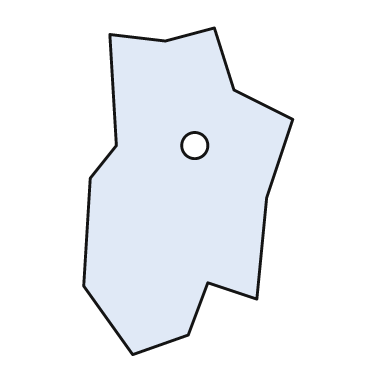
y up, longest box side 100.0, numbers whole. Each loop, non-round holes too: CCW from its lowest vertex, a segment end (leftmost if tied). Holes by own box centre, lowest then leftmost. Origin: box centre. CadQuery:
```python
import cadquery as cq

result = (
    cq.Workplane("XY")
    .moveTo(-17.0, -50.0)
    .lineTo(0.0, -44.0)
    .lineTo(6.0, -28.0)
    .lineTo(21.0, -33.0)
    .lineTo(24.0, -2.0)
    .lineTo(32.0, 22.0)
    .lineTo(14.0, 31.0)
    .lineTo(8.0, 50.0)
    .lineTo(-7.0, 46.0)
    .lineTo(-24.0, 48.0)
    .lineTo(-22.0, 14.0)
    .lineTo(-30.0, 4.0)
    .lineTo(-32.0, -29.0)
    .close()
    .moveTo(2.0, 14.0)
    .circle(4.0)
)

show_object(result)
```